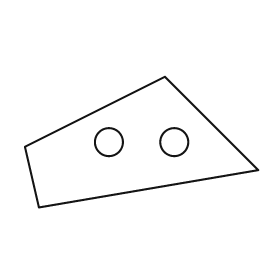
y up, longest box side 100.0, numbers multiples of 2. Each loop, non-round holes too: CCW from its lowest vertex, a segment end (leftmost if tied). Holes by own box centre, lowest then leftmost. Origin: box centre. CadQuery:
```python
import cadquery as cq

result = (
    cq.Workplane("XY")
    .moveTo(-44.0, -28.0)
    .lineTo(50.0, -12.0)
    .lineTo(10.0, 28.0)
    .lineTo(-50.0, -2.0)
    .close()
    .moveTo(-14.0, 0.0)
    .circle(6.0)
    .moveTo(14.0, 0.0)
    .circle(6.0)
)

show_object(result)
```